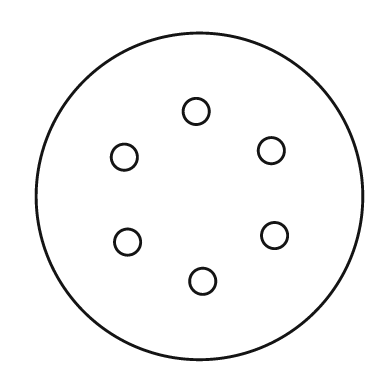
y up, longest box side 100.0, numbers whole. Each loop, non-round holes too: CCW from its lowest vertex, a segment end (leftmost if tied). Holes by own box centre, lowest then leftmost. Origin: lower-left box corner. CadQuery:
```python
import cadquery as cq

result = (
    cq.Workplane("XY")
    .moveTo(50.0, 50.0)
    .circle(50.0)
    .moveTo(51.0, 24.0)
    .circle(4.0)
    .moveTo(28.0, 36.0)
    .circle(4.0)
    .moveTo(73.0, 38.0)
    .circle(4.0)
    .moveTo(27.0, 62.0)
    .circle(4.0)
    .moveTo(72.0, 64.0)
    .circle(4.0)
    .moveTo(49.0, 76.0)
    .circle(4.0)
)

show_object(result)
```